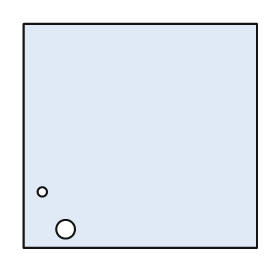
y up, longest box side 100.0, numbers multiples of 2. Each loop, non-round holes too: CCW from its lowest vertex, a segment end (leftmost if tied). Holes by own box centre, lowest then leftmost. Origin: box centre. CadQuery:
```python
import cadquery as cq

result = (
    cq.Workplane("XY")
    .moveTo(-50.0, -48.0)
    .lineTo(50.0, -48.0)
    .lineTo(50.0, 48.0)
    .lineTo(-50.0, 48.0)
    .close()
    .moveTo(-32.0, -40.0)
    .circle(4.0)
    .moveTo(-42.0, -24.0)
    .circle(2.0)
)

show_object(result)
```